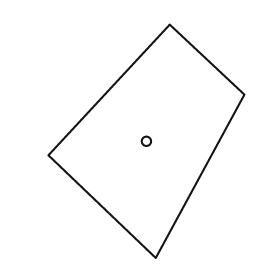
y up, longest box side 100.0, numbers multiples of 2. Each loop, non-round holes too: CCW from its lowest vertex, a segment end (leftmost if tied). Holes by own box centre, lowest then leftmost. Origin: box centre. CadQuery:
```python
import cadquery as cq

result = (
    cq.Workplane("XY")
    .moveTo(4.0, -50.0)
    .lineTo(42.0, 20.0)
    .lineTo(10.0, 50.0)
    .lineTo(-42.0, -6.0)
    .close()
    .moveTo(0.0, 0.0)
    .circle(2.0)
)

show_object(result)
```